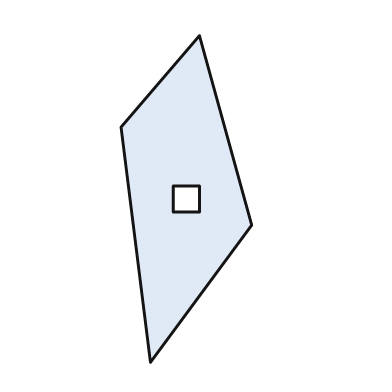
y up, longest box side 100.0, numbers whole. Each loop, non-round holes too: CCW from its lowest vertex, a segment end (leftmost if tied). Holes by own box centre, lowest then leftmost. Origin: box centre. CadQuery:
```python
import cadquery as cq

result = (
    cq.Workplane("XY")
    .moveTo(-11.0, -50.0)
    .lineTo(20.0, -8.0)
    .lineTo(4.0, 50.0)
    .lineTo(-20.0, 22.0)
    .close()
    .moveTo(-4.0, -4.0)
    .lineTo(4.0, -4.0)
    .lineTo(4.0, 4.0)
    .lineTo(-4.0, 4.0)
    .close()
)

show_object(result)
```